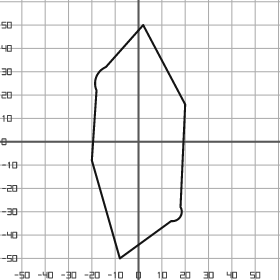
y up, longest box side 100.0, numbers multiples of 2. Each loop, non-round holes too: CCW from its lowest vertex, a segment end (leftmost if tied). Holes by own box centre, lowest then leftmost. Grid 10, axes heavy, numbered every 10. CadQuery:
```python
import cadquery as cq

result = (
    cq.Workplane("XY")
    .moveTo(-8.0, -50.0)
    .lineTo(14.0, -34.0)
    .threePointArc((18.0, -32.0), (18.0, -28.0))
    .lineTo(20.0, 16.0)
    .lineTo(2.0, 50.0)
    .lineTo(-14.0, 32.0)
    .threePointArc((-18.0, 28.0), (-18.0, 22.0))
    .lineTo(-20.0, -8.0)
    .close()
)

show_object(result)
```